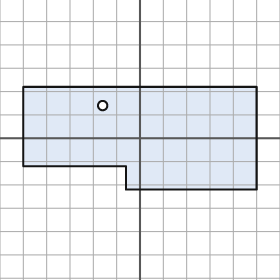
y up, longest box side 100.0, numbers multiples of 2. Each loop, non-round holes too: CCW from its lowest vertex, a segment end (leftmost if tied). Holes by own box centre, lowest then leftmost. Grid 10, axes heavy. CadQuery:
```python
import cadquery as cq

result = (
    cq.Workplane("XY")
    .moveTo(-6.0, -22.0)
    .lineTo(50.0, -22.0)
    .lineTo(50.0, 22.0)
    .lineTo(-50.0, 22.0)
    .lineTo(-50.0, -12.0)
    .lineTo(-6.0, -12.0)
    .close()
    .moveTo(-16.0, 14.0)
    .circle(2.0)
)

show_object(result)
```